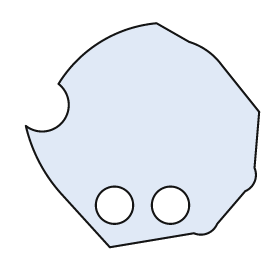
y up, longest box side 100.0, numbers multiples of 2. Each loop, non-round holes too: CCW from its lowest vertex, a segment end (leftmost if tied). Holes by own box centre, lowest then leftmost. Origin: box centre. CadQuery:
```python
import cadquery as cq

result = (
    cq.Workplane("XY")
    .moveTo(-14.0, -48.0)
    .lineTo(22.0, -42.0)
    .threePointArc((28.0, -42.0), (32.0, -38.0))
    .lineTo(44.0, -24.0)
    .threePointArc((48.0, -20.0), (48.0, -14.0))
    .lineTo(50.0, 10.0)
    .lineTo(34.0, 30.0)
    .threePointArc((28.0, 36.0), (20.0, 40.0))
    .lineTo(6.0, 48.0)
    .threePointArc((-18.0, 40.0), (-36.0, 22.0))
    .threePointArc((-34.0, 6.0), (-50.0, 4.0))
    .threePointArc((-44.0, -12.0), (-34.0, -26.0))
    .close()
    .moveTo(-12.0, -30.0)
    .circle(8.0)
    .moveTo(12.0, -30.0)
    .circle(8.0)
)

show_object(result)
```